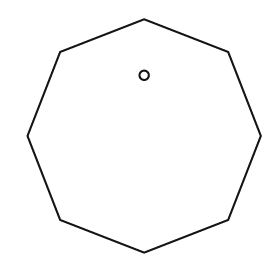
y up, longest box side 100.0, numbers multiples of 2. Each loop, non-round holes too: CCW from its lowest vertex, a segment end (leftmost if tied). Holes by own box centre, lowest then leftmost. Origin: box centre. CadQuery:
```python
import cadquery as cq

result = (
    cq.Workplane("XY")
    .moveTo(0.0, -50.0)
    .lineTo(36.0, -36.0)
    .lineTo(50.0, 0.0)
    .lineTo(36.0, 36.0)
    .lineTo(0.0, 50.0)
    .lineTo(-36.0, 36.0)
    .lineTo(-50.0, 0.0)
    .lineTo(-36.0, -36.0)
    .close()
    .moveTo(0.0, 26.0)
    .circle(2.0)
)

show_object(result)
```